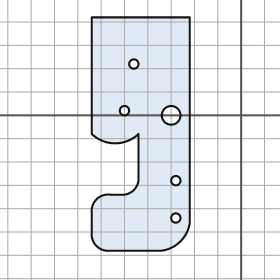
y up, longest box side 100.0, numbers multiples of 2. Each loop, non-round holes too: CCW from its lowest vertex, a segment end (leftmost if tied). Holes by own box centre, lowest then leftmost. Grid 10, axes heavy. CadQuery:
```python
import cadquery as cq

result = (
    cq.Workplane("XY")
    .moveTo(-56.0, -58.0)
    .lineTo(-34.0, -58.0)
    .threePointArc((-26.0, -54.0), (-22.0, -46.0))
    .lineTo(-22.0, 42.0)
    .lineTo(-64.0, 42.0)
    .lineTo(-64.0, -8.0)
    .threePointArc((-54.0, -12.0), (-44.0, -8.0))
    .lineTo(-44.0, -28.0)
    .threePointArc((-46.0, -32.0), (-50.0, -34.0))
    .lineTo(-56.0, -34.0)
    .threePointArc((-62.0, -36.0), (-64.0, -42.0))
    .lineTo(-64.0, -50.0)
    .threePointArc((-62.0, -56.0), (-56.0, -58.0))
    .close()
    .moveTo(-28.0, -44.0)
    .circle(2.0)
    .moveTo(-28.0, -28.0)
    .circle(2.0)
    .moveTo(-30.0, 0.0)
    .circle(4.0)
    .moveTo(-50.0, 2.0)
    .circle(2.0)
    .moveTo(-46.0, 22.0)
    .circle(2.0)
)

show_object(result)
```